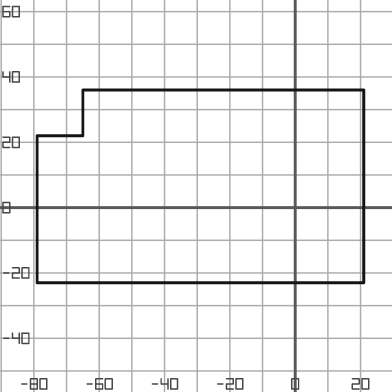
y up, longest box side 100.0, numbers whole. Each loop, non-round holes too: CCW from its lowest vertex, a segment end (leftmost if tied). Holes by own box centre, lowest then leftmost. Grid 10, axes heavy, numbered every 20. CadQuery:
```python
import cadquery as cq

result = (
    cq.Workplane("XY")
    .moveTo(-79.0, -23.0)
    .lineTo(21.0, -23.0)
    .lineTo(21.0, 36.0)
    .lineTo(-65.0, 36.0)
    .lineTo(-65.0, 22.0)
    .lineTo(-79.0, 22.0)
    .close()
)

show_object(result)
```